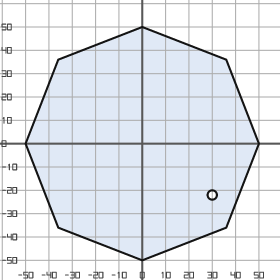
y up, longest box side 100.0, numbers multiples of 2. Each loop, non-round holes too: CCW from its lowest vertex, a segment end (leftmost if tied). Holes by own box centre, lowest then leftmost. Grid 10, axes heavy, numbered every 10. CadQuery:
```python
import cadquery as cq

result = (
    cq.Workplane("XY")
    .moveTo(0.0, -50.0)
    .lineTo(36.0, -36.0)
    .lineTo(50.0, 0.0)
    .lineTo(36.0, 36.0)
    .lineTo(0.0, 50.0)
    .lineTo(-36.0, 36.0)
    .lineTo(-50.0, 0.0)
    .lineTo(-36.0, -36.0)
    .close()
    .moveTo(30.0, -22.0)
    .circle(2.0)
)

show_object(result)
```